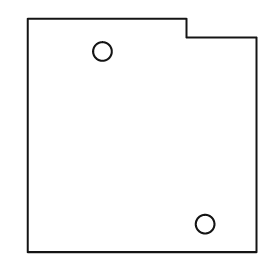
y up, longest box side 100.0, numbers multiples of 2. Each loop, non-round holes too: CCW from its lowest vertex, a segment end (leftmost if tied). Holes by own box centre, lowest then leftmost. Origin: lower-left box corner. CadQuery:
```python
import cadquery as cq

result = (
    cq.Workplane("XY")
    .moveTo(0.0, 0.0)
    .lineTo(98.0, 0.0)
    .lineTo(98.0, 92.0)
    .lineTo(68.0, 92.0)
    .lineTo(68.0, 100.0)
    .lineTo(0.0, 100.0)
    .close()
    .moveTo(76.0, 12.0)
    .circle(4.0)
    .moveTo(32.0, 86.0)
    .circle(4.0)
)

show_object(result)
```